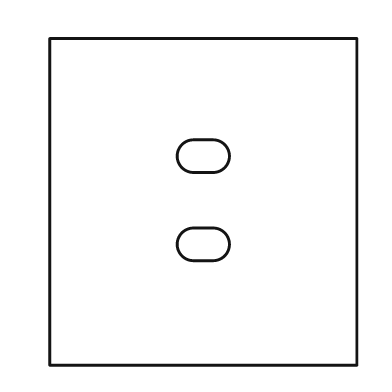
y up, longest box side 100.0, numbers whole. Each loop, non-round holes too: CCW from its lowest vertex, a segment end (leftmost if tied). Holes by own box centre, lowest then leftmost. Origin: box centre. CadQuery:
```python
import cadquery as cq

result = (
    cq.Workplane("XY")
    .moveTo(-47.0, -50.0)
    .lineTo(47.0, -50.0)
    .lineTo(47.0, 50.0)
    .lineTo(-47.0, 50.0)
    .close()
    .moveTo(-3.0, -18.0)
    .lineTo(3.0, -18.0)
    .threePointArc((8.0, -13.0), (3.0, -8.0))
    .lineTo(-3.0, -8.0)
    .threePointArc((-8.0, -13.0), (-3.0, -18.0))
    .close()
    .moveTo(-3.0, 9.0)
    .lineTo(3.0, 9.0)
    .threePointArc((8.0, 14.0), (3.0, 19.0))
    .lineTo(-3.0, 19.0)
    .threePointArc((-8.0, 14.0), (-3.0, 9.0))
    .close()
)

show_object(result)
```